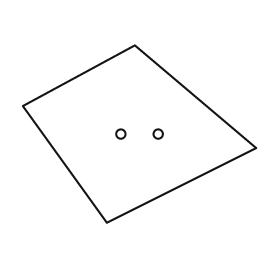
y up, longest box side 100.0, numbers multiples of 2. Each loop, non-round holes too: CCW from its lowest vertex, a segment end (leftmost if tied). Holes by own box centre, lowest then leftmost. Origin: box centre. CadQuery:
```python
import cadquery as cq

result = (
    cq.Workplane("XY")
    .moveTo(-14.0, -38.0)
    .lineTo(50.0, -6.0)
    .lineTo(-2.0, 38.0)
    .lineTo(-50.0, 12.0)
    .close()
    .moveTo(-8.0, 0.0)
    .circle(2.0)
    .moveTo(8.0, 0.0)
    .circle(2.0)
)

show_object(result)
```